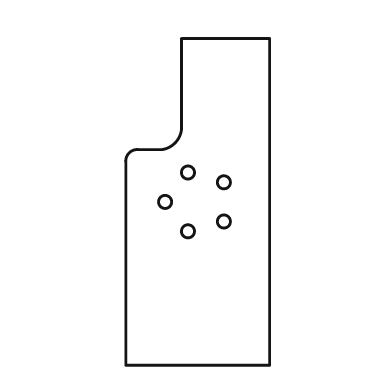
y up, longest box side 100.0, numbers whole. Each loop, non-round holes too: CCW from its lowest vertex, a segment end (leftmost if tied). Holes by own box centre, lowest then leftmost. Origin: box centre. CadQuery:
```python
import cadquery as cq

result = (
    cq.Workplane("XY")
    .moveTo(-22.0, -50.0)
    .lineTo(22.0, -50.0)
    .lineTo(22.0, 50.0)
    .lineTo(-5.0, 50.0)
    .lineTo(-5.0, 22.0)
    .threePointArc((-7.0, 18.0), (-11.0, 16.0))
    .lineTo(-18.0, 16.0)
    .threePointArc((-21.0, 15.0), (-22.0, 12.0))
    .close()
    .moveTo(-3.0, -9.0)
    .circle(2.0)
    .moveTo(8.0, -6.0)
    .circle(2.0)
    .moveTo(-10.0, 0.0)
    .circle(2.0)
    .moveTo(8.0, 6.0)
    .circle(2.0)
    .moveTo(-3.0, 9.0)
    .circle(2.0)
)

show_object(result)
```